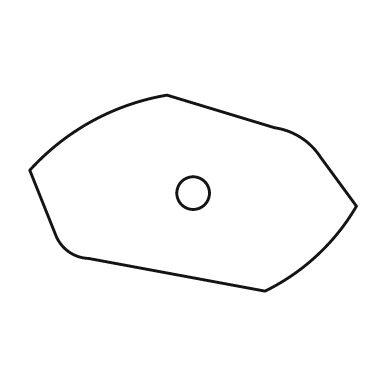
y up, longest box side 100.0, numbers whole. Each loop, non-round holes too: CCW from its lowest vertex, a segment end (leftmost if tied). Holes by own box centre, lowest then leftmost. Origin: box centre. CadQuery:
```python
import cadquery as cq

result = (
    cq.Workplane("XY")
    .moveTo(22.0, -30.0)
    .threePointArc((38.0, -19.0), (50.0, -4.0))
    .lineTo(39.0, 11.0)
    .threePointArc((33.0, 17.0), (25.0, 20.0))
    .lineTo(-8.0, 30.0)
    .threePointArc((-31.0, 22.0), (-50.0, 7.0))
    .lineTo(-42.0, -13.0)
    .threePointArc((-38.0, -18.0), (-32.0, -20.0))
    .close()
    .moveTo(0.0, 0.0)
    .circle(5.0)
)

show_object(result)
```